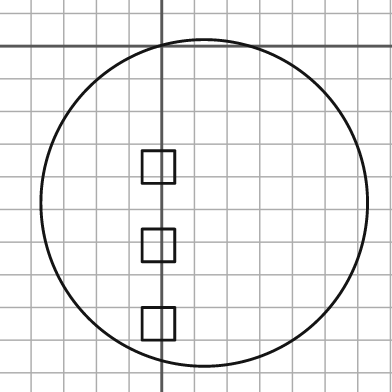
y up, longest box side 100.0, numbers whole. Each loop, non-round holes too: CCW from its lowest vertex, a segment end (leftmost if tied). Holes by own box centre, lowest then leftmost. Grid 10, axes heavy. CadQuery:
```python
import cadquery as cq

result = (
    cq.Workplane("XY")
    .moveTo(13.0, -48.0)
    .circle(50.0)
    .moveTo(-6.0, -90.0)
    .lineTo(4.0, -90.0)
    .lineTo(4.0, -80.0)
    .lineTo(-6.0, -80.0)
    .close()
    .moveTo(-6.0, -66.0)
    .lineTo(4.0, -66.0)
    .lineTo(4.0, -56.0)
    .lineTo(-6.0, -56.0)
    .close()
    .moveTo(-6.0, -42.0)
    .lineTo(4.0, -42.0)
    .lineTo(4.0, -32.0)
    .lineTo(-6.0, -32.0)
    .close()
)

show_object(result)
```